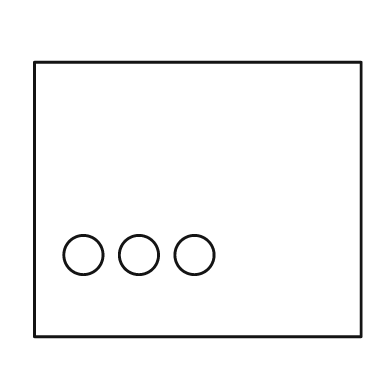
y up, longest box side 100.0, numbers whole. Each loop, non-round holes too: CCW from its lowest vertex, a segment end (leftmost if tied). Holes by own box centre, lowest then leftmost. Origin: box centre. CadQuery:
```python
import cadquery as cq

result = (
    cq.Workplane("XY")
    .moveTo(-50.0, -42.0)
    .lineTo(50.0, -42.0)
    .lineTo(50.0, 42.0)
    .lineTo(-50.0, 42.0)
    .close()
    .moveTo(-35.0, -17.0)
    .circle(6.0)
    .moveTo(-18.0, -17.0)
    .circle(6.0)
    .moveTo(-1.0, -17.0)
    .circle(6.0)
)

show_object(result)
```